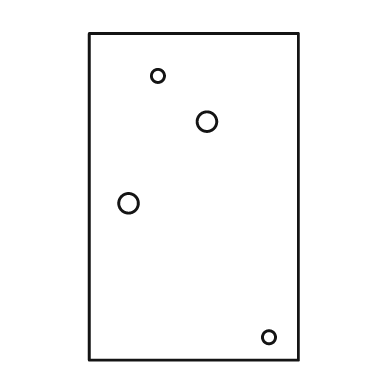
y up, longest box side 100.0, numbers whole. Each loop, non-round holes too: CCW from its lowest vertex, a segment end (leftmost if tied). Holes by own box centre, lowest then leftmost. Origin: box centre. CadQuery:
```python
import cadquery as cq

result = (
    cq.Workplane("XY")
    .moveTo(-32.0, -50.0)
    .lineTo(32.0, -50.0)
    .lineTo(32.0, 50.0)
    .lineTo(-32.0, 50.0)
    .close()
    .moveTo(23.0, -43.0)
    .circle(2.0)
    .moveTo(-20.0, -2.0)
    .circle(3.0)
    .moveTo(4.0, 23.0)
    .circle(3.0)
    .moveTo(-11.0, 37.0)
    .circle(2.0)
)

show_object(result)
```